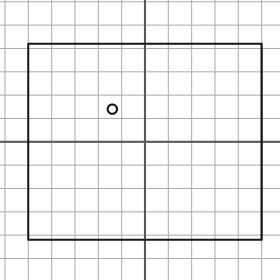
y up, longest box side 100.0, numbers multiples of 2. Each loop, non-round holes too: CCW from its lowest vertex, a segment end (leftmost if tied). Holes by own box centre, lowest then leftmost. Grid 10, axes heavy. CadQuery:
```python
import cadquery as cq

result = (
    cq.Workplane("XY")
    .moveTo(-50.0, -42.0)
    .lineTo(50.0, -42.0)
    .lineTo(50.0, 42.0)
    .lineTo(-50.0, 42.0)
    .close()
    .moveTo(-14.0, 14.0)
    .circle(2.0)
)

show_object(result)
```